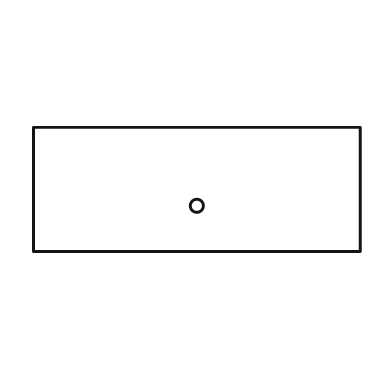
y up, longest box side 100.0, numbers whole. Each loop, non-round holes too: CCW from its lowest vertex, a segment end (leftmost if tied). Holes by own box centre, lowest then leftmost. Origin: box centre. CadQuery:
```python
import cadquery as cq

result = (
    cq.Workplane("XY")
    .moveTo(-50.0, -19.0)
    .lineTo(50.0, -19.0)
    .lineTo(50.0, 19.0)
    .lineTo(-50.0, 19.0)
    .close()
    .moveTo(0.0, -5.0)
    .circle(2.0)
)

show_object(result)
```